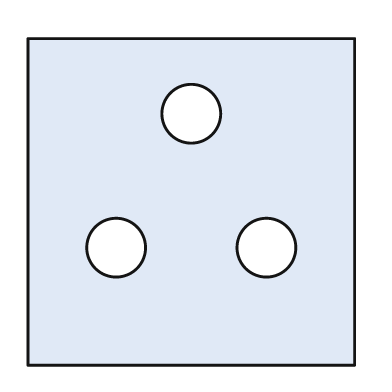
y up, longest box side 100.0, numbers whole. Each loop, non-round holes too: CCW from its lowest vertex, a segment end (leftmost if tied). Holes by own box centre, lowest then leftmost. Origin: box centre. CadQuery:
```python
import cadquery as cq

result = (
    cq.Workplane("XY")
    .moveTo(-50.0, -50.0)
    .lineTo(50.0, -50.0)
    .lineTo(50.0, 50.0)
    .lineTo(-50.0, 50.0)
    .close()
    .moveTo(-23.0, -14.0)
    .circle(9.0)
    .moveTo(23.0, -14.0)
    .circle(9.0)
    .moveTo(0.0, 27.0)
    .circle(9.0)
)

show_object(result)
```